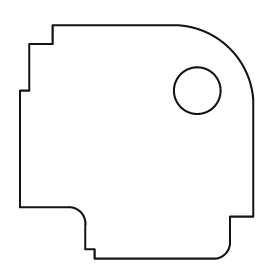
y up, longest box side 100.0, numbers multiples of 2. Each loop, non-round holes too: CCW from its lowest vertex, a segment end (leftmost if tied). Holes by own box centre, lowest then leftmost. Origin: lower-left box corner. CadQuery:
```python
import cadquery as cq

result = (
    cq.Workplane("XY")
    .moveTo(32.0, 0.0)
    .lineTo(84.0, 0.0)
    .threePointArc((88.0, 2.0), (90.0, 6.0))
    .lineTo(90.0, 18.0)
    .lineTo(100.0, 18.0)
    .lineTo(100.0, 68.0)
    .threePointArc((90.0, 90.0), (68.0, 100.0))
    .lineTo(14.0, 100.0)
    .lineTo(14.0, 92.0)
    .lineTo(4.0, 92.0)
    .lineTo(4.0, 72.0)
    .lineTo(0.0, 72.0)
    .lineTo(0.0, 22.0)
    .lineTo(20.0, 22.0)
    .threePointArc((26.0, 20.0), (28.0, 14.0))
    .lineTo(28.0, 4.0)
    .lineTo(32.0, 4.0)
    .close()
    .moveTo(76.0, 72.0)
    .circle(10.0)
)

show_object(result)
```